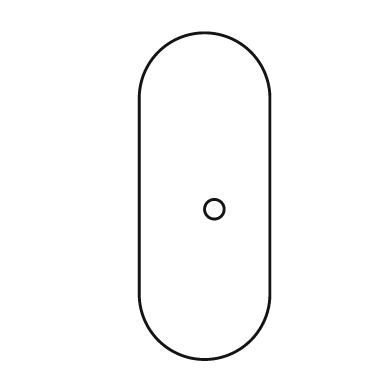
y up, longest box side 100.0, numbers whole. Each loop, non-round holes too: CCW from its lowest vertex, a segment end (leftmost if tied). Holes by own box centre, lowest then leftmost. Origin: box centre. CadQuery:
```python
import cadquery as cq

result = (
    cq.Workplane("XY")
    .moveTo(-20.0, -30.0)
    .threePointArc((0.0, -50.0), (20.0, -30.0))
    .lineTo(20.0, 30.0)
    .threePointArc((0.0, 50.0), (-20.0, 30.0))
    .close()
    .moveTo(3.0, -4.0)
    .circle(3.0)
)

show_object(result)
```